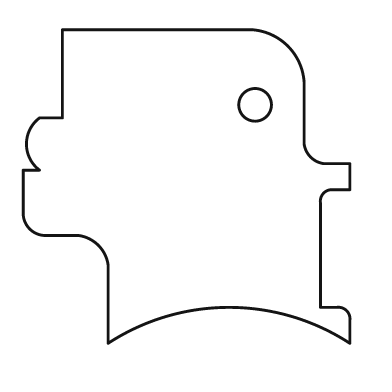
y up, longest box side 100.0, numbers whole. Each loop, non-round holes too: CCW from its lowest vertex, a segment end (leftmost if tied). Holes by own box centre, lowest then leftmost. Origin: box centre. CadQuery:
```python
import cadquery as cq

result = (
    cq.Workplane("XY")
    .moveTo(-24.0, -48.0)
    .threePointArc((13.0, -37.0), (50.0, -48.0))
    .lineTo(50.0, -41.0)
    .threePointArc((49.0, -38.0), (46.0, -37.0))
    .lineTo(41.0, -37.0)
    .lineTo(41.0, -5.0)
    .threePointArc((42.0, -2.0), (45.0, -1.0))
    .lineTo(50.0, -1.0)
    .lineTo(50.0, 7.0)
    .lineTo(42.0, 7.0)
    .threePointArc((38.0, 9.0), (36.0, 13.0))
    .lineTo(36.0, 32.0)
    .threePointArc((31.0, 43.0), (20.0, 48.0))
    .lineTo(-38.0, 48.0)
    .lineTo(-38.0, 21.0)
    .lineTo(-45.0, 21.0)
    .threePointArc((-49.0, 13.0), (-45.0, 5.0))
    .lineTo(-50.0, 5.0)
    .lineTo(-50.0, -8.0)
    .threePointArc((-48.0, -13.0), (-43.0, -15.0))
    .lineTo(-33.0, -15.0)
    .threePointArc((-27.0, -18.0), (-24.0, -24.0))
    .close()
    .moveTo(21.0, 25.0)
    .circle(5.0)
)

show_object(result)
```